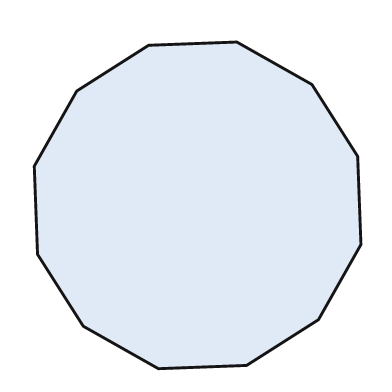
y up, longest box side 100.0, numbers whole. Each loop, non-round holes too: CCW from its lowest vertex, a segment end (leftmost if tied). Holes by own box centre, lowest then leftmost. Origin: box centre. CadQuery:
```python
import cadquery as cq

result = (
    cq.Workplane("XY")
    .moveTo(-12.0, -50.0)
    .lineTo(15.0, -49.0)
    .lineTo(37.0, -35.0)
    .lineTo(50.0, -12.0)
    .lineTo(49.0, 15.0)
    .lineTo(35.0, 37.0)
    .lineTo(12.0, 50.0)
    .lineTo(-15.0, 49.0)
    .lineTo(-37.0, 35.0)
    .lineTo(-50.0, 12.0)
    .lineTo(-49.0, -15.0)
    .lineTo(-35.0, -37.0)
    .close()
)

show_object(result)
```